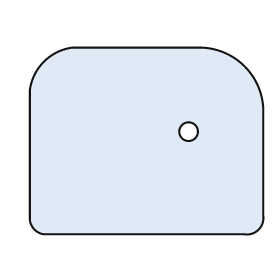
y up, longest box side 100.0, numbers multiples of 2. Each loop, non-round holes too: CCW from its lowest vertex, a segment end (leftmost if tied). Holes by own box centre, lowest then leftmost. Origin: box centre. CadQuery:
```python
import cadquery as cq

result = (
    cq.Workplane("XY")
    .moveTo(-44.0, -40.0)
    .lineTo(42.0, -40.0)
    .threePointArc((48.0, -38.0), (50.0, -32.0))
    .lineTo(50.0, 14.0)
    .threePointArc((42.0, 32.0), (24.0, 40.0))
    .lineTo(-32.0, 40.0)
    .threePointArc((-44.0, 34.0), (-50.0, 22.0))
    .lineTo(-50.0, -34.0)
    .threePointArc((-48.0, -38.0), (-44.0, -40.0))
    .close()
    .moveTo(18.0, 4.0)
    .circle(4.0)
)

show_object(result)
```